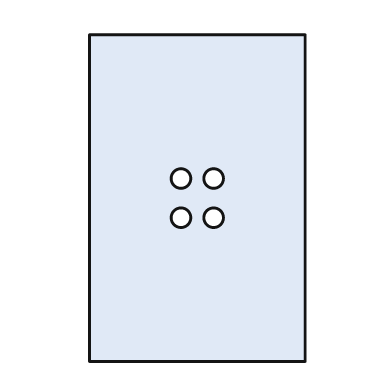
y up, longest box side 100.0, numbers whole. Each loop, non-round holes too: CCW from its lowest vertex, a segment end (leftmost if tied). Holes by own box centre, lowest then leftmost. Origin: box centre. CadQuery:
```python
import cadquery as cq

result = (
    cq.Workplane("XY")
    .moveTo(-33.0, -50.0)
    .lineTo(33.0, -50.0)
    .lineTo(33.0, 50.0)
    .lineTo(-33.0, 50.0)
    .close()
    .moveTo(-5.0, -6.0)
    .circle(3.0)
    .moveTo(5.0, -6.0)
    .circle(3.0)
    .moveTo(-5.0, 6.0)
    .circle(3.0)
    .moveTo(5.0, 6.0)
    .circle(3.0)
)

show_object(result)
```